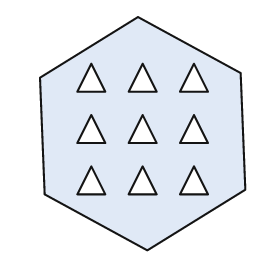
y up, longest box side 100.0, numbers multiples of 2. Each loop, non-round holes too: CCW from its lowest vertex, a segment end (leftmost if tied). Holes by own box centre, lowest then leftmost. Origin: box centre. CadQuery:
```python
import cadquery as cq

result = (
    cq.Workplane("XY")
    .moveTo(2.0, -50.0)
    .lineTo(44.0, -24.0)
    .lineTo(42.0, 26.0)
    .lineTo(-2.0, 50.0)
    .lineTo(-44.0, 24.0)
    .lineTo(-42.0, -26.0)
    .close()
    .moveTo(-28.0, -26.0)
    .lineTo(-16.0, -26.0)
    .lineTo(-22.0, -14.0)
    .close()
    .moveTo(-6.0, -26.0)
    .lineTo(6.0, -26.0)
    .lineTo(0.0, -14.0)
    .close()
    .moveTo(16.0, -26.0)
    .lineTo(28.0, -26.0)
    .lineTo(22.0, -14.0)
    .close()
    .moveTo(-28.0, -4.0)
    .lineTo(-16.0, -4.0)
    .lineTo(-22.0, 8.0)
    .close()
    .moveTo(-6.0, -4.0)
    .lineTo(6.0, -4.0)
    .lineTo(0.0, 8.0)
    .close()
    .moveTo(16.0, -4.0)
    .lineTo(28.0, -4.0)
    .lineTo(22.0, 8.0)
    .close()
    .moveTo(-28.0, 18.0)
    .lineTo(-16.0, 18.0)
    .lineTo(-22.0, 30.0)
    .close()
    .moveTo(-6.0, 18.0)
    .lineTo(6.0, 18.0)
    .lineTo(0.0, 30.0)
    .close()
    .moveTo(16.0, 18.0)
    .lineTo(28.0, 18.0)
    .lineTo(22.0, 30.0)
    .close()
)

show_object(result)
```